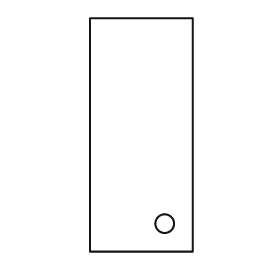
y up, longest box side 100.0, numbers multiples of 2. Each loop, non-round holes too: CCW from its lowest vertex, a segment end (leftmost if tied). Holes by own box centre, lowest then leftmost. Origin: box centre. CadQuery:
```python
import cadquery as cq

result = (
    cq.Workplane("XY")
    .moveTo(-22.0, -50.0)
    .lineTo(22.0, -50.0)
    .lineTo(22.0, 50.0)
    .lineTo(-22.0, 50.0)
    .close()
    .moveTo(10.0, -38.0)
    .circle(4.0)
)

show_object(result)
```